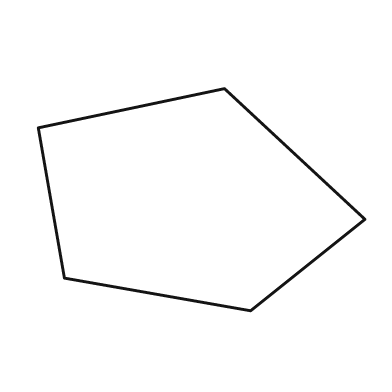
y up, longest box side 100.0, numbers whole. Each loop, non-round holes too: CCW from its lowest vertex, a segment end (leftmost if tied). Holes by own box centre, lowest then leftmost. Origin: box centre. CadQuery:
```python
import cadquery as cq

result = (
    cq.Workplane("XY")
    .moveTo(15.0, -34.0)
    .lineTo(50.0, -6.0)
    .lineTo(7.0, 34.0)
    .lineTo(-50.0, 22.0)
    .lineTo(-42.0, -24.0)
    .close()
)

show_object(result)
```